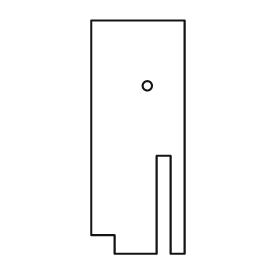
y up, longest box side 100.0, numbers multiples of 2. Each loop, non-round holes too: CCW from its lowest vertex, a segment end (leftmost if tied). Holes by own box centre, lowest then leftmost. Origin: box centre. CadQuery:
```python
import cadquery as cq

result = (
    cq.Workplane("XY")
    .moveTo(-10.0, -50.0)
    .lineTo(8.0, -50.0)
    .lineTo(8.0, -8.0)
    .lineTo(14.0, -8.0)
    .lineTo(14.0, -50.0)
    .lineTo(20.0, -50.0)
    .lineTo(20.0, 50.0)
    .lineTo(-20.0, 50.0)
    .lineTo(-20.0, -42.0)
    .lineTo(-10.0, -42.0)
    .close()
    .moveTo(4.0, 22.0)
    .circle(2.0)
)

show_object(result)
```